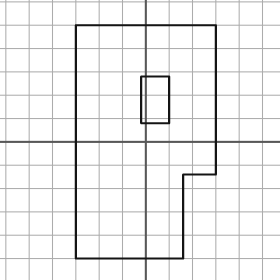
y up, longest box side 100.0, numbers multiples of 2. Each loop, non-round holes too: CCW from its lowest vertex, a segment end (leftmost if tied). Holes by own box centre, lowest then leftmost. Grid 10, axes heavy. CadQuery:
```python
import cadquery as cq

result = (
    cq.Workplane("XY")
    .moveTo(-30.0, -50.0)
    .lineTo(16.0, -50.0)
    .lineTo(16.0, -14.0)
    .lineTo(30.0, -14.0)
    .lineTo(30.0, 50.0)
    .lineTo(-30.0, 50.0)
    .close()
    .moveTo(-2.0, 8.0)
    .lineTo(10.0, 8.0)
    .lineTo(10.0, 28.0)
    .lineTo(-2.0, 28.0)
    .close()
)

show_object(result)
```